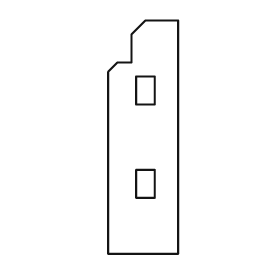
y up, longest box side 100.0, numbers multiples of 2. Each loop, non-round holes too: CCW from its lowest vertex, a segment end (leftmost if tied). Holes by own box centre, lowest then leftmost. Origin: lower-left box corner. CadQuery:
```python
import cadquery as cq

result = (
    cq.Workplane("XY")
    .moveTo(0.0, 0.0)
    .lineTo(30.0, 0.0)
    .lineTo(30.0, 100.0)
    .lineTo(16.0, 100.0)
    .lineTo(10.0, 94.0)
    .lineTo(10.0, 82.0)
    .lineTo(4.0, 82.0)
    .lineTo(0.0, 78.0)
    .close()
    .moveTo(12.0, 24.0)
    .lineTo(20.0, 24.0)
    .lineTo(20.0, 36.0)
    .lineTo(12.0, 36.0)
    .close()
    .moveTo(12.0, 64.0)
    .lineTo(20.0, 64.0)
    .lineTo(20.0, 76.0)
    .lineTo(12.0, 76.0)
    .close()
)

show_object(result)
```